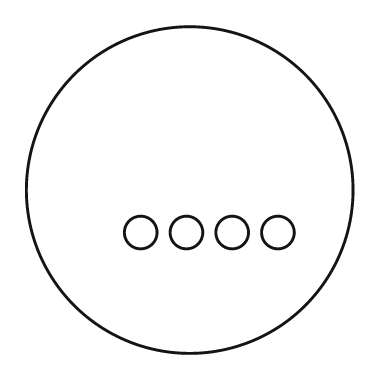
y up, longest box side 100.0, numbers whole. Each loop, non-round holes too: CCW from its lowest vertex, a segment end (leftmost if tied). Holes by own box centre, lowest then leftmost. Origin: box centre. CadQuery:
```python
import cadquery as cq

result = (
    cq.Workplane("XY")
    .moveTo(0.0, 0.0)
    .circle(50.0)
    .moveTo(-15.0, -13.0)
    .circle(5.0)
    .moveTo(-1.0, -13.0)
    .circle(5.0)
    .moveTo(13.0, -13.0)
    .circle(5.0)
    .moveTo(27.0, -13.0)
    .circle(5.0)
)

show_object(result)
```